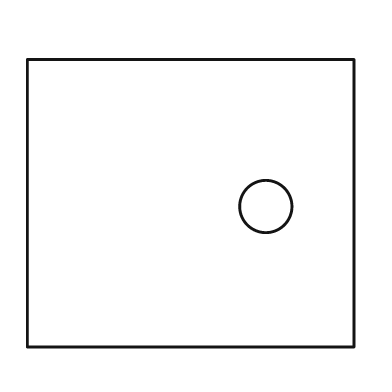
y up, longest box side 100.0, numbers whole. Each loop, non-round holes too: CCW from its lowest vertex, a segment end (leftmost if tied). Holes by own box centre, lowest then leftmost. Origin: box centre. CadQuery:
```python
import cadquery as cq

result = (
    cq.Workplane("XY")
    .moveTo(-50.0, -44.0)
    .lineTo(50.0, -44.0)
    .lineTo(50.0, 44.0)
    .lineTo(-50.0, 44.0)
    .close()
    .moveTo(23.0, -1.0)
    .circle(8.0)
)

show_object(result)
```